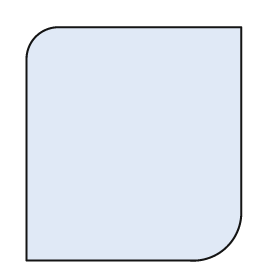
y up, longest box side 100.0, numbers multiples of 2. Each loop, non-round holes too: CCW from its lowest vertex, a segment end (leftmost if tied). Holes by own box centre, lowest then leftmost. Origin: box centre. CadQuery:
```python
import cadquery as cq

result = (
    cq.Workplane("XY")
    .moveTo(-46.0, -50.0)
    .lineTo(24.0, -50.0)
    .threePointArc((40.0, -44.0), (46.0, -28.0))
    .lineTo(46.0, 50.0)
    .lineTo(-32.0, 50.0)
    .threePointArc((-42.0, 46.0), (-46.0, 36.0))
    .close()
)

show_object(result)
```